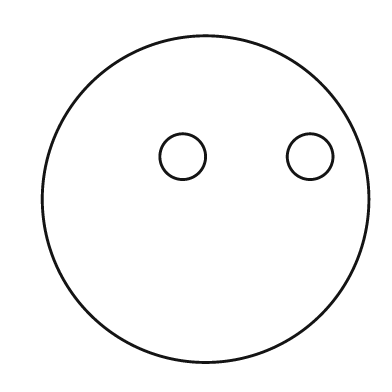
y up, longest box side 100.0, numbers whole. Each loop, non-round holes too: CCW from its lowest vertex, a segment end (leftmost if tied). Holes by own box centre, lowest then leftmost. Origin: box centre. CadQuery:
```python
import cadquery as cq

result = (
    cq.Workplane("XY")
    .moveTo(0.0, 0.0)
    .circle(50.0)
    .moveTo(-7.0, 13.0)
    .circle(7.0)
    .moveTo(32.0, 13.0)
    .circle(7.0)
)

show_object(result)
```